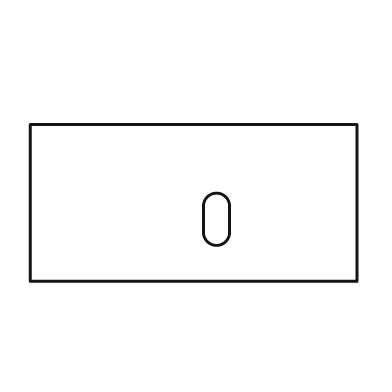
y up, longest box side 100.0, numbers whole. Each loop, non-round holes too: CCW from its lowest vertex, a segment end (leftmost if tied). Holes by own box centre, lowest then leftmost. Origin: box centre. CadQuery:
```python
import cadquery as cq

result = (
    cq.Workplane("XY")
    .moveTo(-50.0, -24.0)
    .lineTo(50.0, -24.0)
    .lineTo(50.0, 24.0)
    .lineTo(-50.0, 24.0)
    .close()
    .moveTo(3.0, -9.0)
    .threePointArc((7.0, -13.0), (11.0, -9.0))
    .lineTo(11.0, -1.0)
    .threePointArc((7.0, 3.0), (3.0, -1.0))
    .close()
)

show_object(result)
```